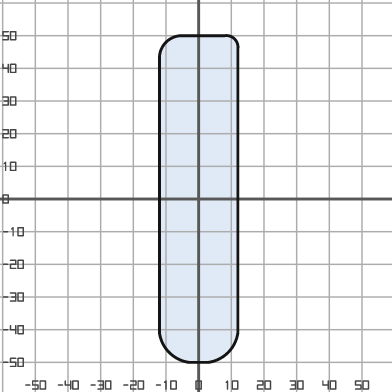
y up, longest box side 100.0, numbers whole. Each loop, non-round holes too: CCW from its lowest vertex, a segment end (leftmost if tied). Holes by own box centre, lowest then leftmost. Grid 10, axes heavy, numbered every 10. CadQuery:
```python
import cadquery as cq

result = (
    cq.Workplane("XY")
    .moveTo(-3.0, -50.0)
    .lineTo(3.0, -50.0)
    .threePointArc((9.0, -47.0), (12.0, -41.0))
    .lineTo(12.0, 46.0)
    .threePointArc((11.0, 49.0), (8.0, 50.0))
    .lineTo(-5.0, 50.0)
    .threePointArc((-10.0, 48.0), (-12.0, 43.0))
    .lineTo(-12.0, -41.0)
    .threePointArc((-9.0, -47.0), (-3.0, -50.0))
    .close()
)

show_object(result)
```